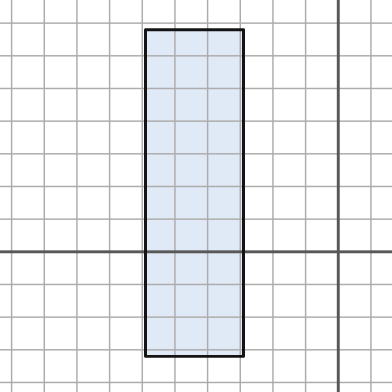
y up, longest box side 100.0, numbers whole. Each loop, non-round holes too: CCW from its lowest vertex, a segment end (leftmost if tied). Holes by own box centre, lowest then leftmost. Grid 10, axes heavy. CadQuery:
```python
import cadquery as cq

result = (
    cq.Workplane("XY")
    .moveTo(-59.0, -32.0)
    .lineTo(-29.0, -32.0)
    .lineTo(-29.0, 68.0)
    .lineTo(-59.0, 68.0)
    .close()
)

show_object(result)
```